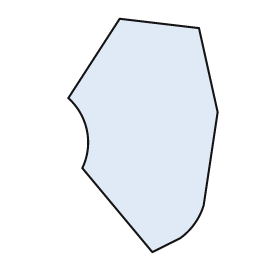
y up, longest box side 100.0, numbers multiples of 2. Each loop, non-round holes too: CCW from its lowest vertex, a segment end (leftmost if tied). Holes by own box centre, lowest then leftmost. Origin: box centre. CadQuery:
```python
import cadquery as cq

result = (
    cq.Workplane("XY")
    .moveTo(4.0, -50.0)
    .lineTo(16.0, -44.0)
    .threePointArc((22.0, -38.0), (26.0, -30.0))
    .lineTo(32.0, 10.0)
    .lineTo(24.0, 46.0)
    .lineTo(-10.0, 50.0)
    .lineTo(-32.0, 16.0)
    .threePointArc((-24.0, 2.0), (-26.0, -14.0))
    .close()
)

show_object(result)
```